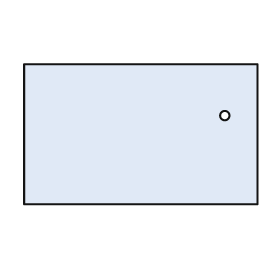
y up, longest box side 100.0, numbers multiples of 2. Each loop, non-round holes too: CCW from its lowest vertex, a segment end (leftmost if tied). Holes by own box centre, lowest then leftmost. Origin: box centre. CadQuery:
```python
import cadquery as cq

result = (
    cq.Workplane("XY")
    .moveTo(-50.0, -30.0)
    .lineTo(50.0, -30.0)
    .lineTo(50.0, 30.0)
    .lineTo(-50.0, 30.0)
    .close()
    .moveTo(36.0, 8.0)
    .circle(2.0)
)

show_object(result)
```